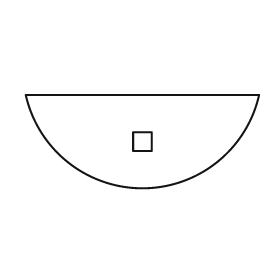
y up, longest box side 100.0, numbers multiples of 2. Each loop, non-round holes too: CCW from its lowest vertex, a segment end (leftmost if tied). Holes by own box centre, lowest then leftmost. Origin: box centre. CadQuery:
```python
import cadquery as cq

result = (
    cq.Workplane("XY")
    .moveTo(-50.0, 20.0)
    .threePointArc((0.0, -20.0), (50.0, 20.0))
    .close()
    .moveTo(-4.0, -4.0)
    .lineTo(4.0, -4.0)
    .lineTo(4.0, 4.0)
    .lineTo(-4.0, 4.0)
    .close()
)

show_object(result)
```